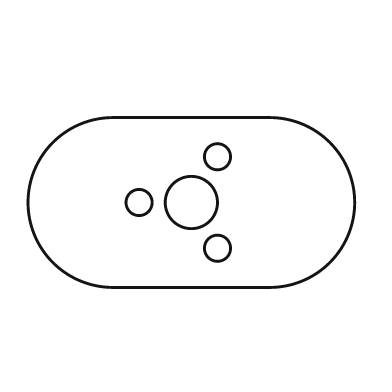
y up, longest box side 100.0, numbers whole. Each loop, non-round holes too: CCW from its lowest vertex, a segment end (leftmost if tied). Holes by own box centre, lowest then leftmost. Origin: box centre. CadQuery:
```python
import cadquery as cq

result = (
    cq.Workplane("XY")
    .moveTo(-24.0, -26.0)
    .lineTo(24.0, -26.0)
    .threePointArc((50.0, 0.0), (24.0, 26.0))
    .lineTo(-24.0, 26.0)
    .threePointArc((-50.0, 0.0), (-24.0, -26.0))
    .close()
    .moveTo(8.0, -14.0)
    .circle(4.0)
    .moveTo(-16.0, 0.0)
    .circle(4.0)
    .moveTo(0.0, 0.0)
    .circle(8.0)
    .moveTo(8.0, 14.0)
    .circle(4.0)
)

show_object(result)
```